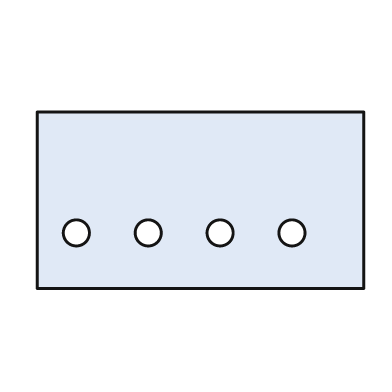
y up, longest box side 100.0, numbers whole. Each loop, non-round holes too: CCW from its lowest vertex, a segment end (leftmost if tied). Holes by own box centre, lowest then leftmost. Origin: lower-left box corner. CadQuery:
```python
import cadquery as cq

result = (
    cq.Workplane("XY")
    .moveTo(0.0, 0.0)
    .lineTo(100.0, 0.0)
    .lineTo(100.0, 54.0)
    .lineTo(0.0, 54.0)
    .close()
    .moveTo(12.0, 17.0)
    .circle(4.0)
    .moveTo(34.0, 17.0)
    .circle(4.0)
    .moveTo(56.0, 17.0)
    .circle(4.0)
    .moveTo(78.0, 17.0)
    .circle(4.0)
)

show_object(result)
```